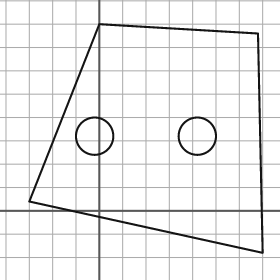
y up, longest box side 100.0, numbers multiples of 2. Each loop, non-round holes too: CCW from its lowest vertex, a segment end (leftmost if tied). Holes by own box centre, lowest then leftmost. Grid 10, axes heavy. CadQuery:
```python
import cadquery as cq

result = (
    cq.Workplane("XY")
    .moveTo(70.0, -18.0)
    .lineTo(68.0, 76.0)
    .lineTo(0.0, 80.0)
    .lineTo(-30.0, 4.0)
    .close()
    .moveTo(-2.0, 32.0)
    .circle(8.0)
    .moveTo(42.0, 32.0)
    .circle(8.0)
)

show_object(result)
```